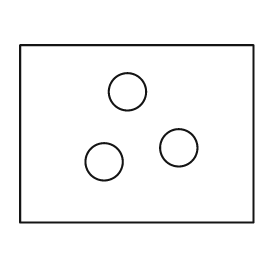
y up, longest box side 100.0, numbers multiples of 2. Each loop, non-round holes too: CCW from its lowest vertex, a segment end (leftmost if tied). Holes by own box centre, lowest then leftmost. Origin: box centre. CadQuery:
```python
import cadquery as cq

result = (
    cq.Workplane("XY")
    .moveTo(-50.0, -38.0)
    .lineTo(50.0, -38.0)
    .lineTo(50.0, 38.0)
    .lineTo(-50.0, 38.0)
    .close()
    .moveTo(-14.0, -12.0)
    .circle(8.0)
    .moveTo(18.0, -6.0)
    .circle(8.0)
    .moveTo(-4.0, 18.0)
    .circle(8.0)
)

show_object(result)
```